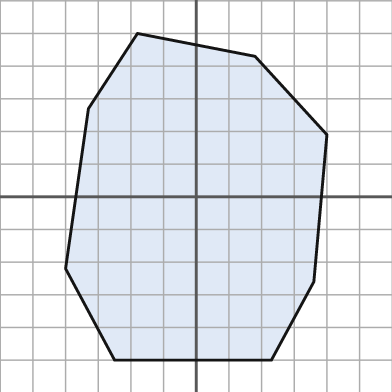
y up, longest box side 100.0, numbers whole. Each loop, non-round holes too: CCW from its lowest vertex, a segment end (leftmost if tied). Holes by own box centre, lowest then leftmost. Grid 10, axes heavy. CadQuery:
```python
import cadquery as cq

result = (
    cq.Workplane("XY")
    .moveTo(-25.0, -50.0)
    .lineTo(23.0, -50.0)
    .lineTo(36.0, -26.0)
    .lineTo(40.0, 19.0)
    .lineTo(18.0, 43.0)
    .lineTo(-18.0, 50.0)
    .lineTo(-33.0, 27.0)
    .lineTo(-40.0, -22.0)
    .close()
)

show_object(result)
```